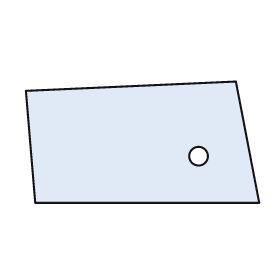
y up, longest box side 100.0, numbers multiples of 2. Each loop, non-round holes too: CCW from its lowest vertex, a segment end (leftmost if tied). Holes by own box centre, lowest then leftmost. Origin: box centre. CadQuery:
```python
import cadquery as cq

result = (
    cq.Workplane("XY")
    .moveTo(-46.0, -26.0)
    .lineTo(50.0, -26.0)
    .lineTo(40.0, 26.0)
    .lineTo(-50.0, 22.0)
    .close()
    .moveTo(24.0, -6.0)
    .circle(4.0)
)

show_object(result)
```